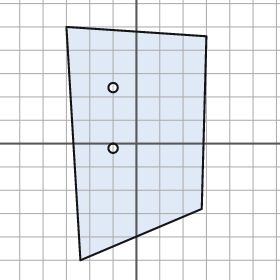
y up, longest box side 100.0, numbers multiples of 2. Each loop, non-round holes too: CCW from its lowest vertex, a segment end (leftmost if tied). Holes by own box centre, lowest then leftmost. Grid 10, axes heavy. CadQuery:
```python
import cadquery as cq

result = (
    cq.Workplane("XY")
    .moveTo(-24.0, -50.0)
    .lineTo(28.0, -28.0)
    .lineTo(30.0, 46.0)
    .lineTo(-30.0, 50.0)
    .close()
    .moveTo(-10.0, -2.0)
    .circle(2.0)
    .moveTo(-10.0, 24.0)
    .circle(2.0)
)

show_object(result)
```